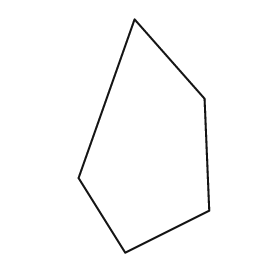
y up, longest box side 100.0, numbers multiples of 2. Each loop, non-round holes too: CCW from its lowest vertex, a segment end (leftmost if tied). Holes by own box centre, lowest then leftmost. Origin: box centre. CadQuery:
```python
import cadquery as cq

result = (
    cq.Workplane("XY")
    .moveTo(-8.0, -50.0)
    .lineTo(28.0, -32.0)
    .lineTo(26.0, 16.0)
    .lineTo(-4.0, 50.0)
    .lineTo(-28.0, -18.0)
    .close()
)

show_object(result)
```